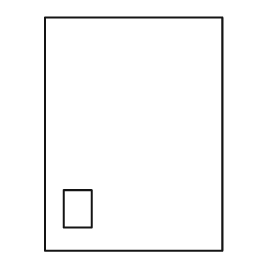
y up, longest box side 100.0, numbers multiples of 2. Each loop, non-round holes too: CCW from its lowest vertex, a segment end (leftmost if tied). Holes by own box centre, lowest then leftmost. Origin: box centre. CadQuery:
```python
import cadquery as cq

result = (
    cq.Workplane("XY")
    .moveTo(-38.0, -50.0)
    .lineTo(38.0, -50.0)
    .lineTo(38.0, 50.0)
    .lineTo(-38.0, 50.0)
    .close()
    .moveTo(-30.0, -40.0)
    .lineTo(-18.0, -40.0)
    .lineTo(-18.0, -24.0)
    .lineTo(-30.0, -24.0)
    .close()
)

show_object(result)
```